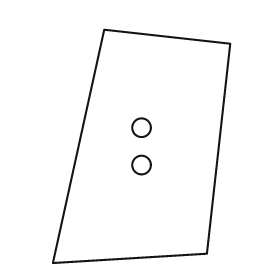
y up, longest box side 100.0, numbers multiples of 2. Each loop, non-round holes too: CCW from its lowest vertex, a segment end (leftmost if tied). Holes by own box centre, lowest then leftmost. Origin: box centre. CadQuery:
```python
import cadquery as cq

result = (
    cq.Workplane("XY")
    .moveTo(-38.0, -50.0)
    .lineTo(28.0, -46.0)
    .lineTo(38.0, 44.0)
    .lineTo(-16.0, 50.0)
    .close()
    .moveTo(0.0, -8.0)
    .circle(4.0)
    .moveTo(0.0, 8.0)
    .circle(4.0)
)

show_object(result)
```